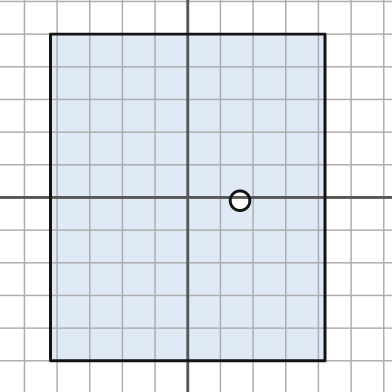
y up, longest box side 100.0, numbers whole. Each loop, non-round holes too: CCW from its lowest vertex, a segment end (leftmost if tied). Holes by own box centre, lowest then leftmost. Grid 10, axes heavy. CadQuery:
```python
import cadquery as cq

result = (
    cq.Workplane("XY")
    .moveTo(-42.0, -50.0)
    .lineTo(42.0, -50.0)
    .lineTo(42.0, 50.0)
    .lineTo(-42.0, 50.0)
    .close()
    .moveTo(16.0, -1.0)
    .circle(3.0)
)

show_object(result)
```